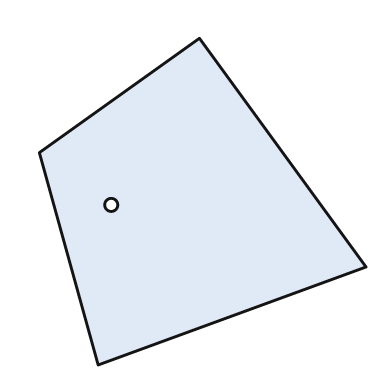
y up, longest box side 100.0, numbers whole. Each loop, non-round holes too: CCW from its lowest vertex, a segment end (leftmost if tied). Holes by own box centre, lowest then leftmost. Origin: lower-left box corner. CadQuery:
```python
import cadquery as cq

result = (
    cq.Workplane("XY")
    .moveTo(18.0, 0.0)
    .lineTo(100.0, 30.0)
    .lineTo(49.0, 100.0)
    .lineTo(0.0, 65.0)
    .close()
    .moveTo(22.0, 49.0)
    .circle(2.0)
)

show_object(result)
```